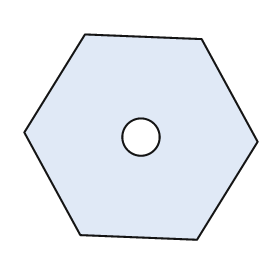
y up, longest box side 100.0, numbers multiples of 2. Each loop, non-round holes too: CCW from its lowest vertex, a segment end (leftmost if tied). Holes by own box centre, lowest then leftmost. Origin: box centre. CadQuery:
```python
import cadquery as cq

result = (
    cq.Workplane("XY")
    .moveTo(24.0, -44.0)
    .lineTo(50.0, -2.0)
    .lineTo(26.0, 42.0)
    .lineTo(-24.0, 44.0)
    .lineTo(-50.0, 2.0)
    .lineTo(-26.0, -42.0)
    .close()
    .moveTo(0.0, 0.0)
    .circle(8.0)
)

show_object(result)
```